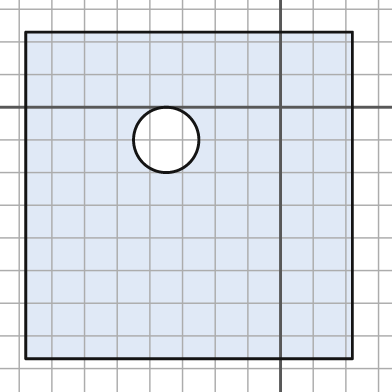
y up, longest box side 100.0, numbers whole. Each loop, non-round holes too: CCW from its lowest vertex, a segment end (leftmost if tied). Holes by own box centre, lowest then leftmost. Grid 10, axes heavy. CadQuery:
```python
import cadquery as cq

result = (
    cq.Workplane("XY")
    .moveTo(-78.0, -77.0)
    .lineTo(22.0, -77.0)
    .lineTo(22.0, 23.0)
    .lineTo(-78.0, 23.0)
    .close()
    .moveTo(-35.0, -10.0)
    .circle(10.0)
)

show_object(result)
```